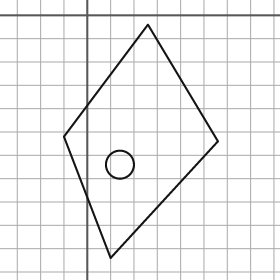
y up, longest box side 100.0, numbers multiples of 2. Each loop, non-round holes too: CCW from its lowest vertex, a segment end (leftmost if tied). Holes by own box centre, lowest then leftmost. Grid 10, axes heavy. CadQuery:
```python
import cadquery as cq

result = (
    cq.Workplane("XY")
    .moveTo(10.0, -104.0)
    .lineTo(56.0, -54.0)
    .lineTo(26.0, -4.0)
    .lineTo(-10.0, -52.0)
    .close()
    .moveTo(14.0, -64.0)
    .circle(6.0)
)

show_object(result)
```